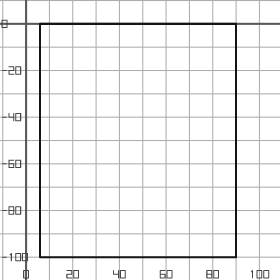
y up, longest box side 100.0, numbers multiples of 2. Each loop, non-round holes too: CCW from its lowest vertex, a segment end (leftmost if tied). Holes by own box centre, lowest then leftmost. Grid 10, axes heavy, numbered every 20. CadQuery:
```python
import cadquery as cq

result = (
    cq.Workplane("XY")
    .moveTo(6.0, -100.0)
    .lineTo(90.0, -100.0)
    .lineTo(90.0, 0.0)
    .lineTo(6.0, 0.0)
    .close()
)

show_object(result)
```